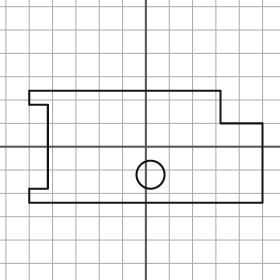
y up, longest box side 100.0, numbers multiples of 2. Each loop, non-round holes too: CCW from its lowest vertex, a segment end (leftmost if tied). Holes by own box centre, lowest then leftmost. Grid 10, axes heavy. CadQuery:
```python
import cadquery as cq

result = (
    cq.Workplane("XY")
    .moveTo(-50.0, -24.0)
    .lineTo(50.0, -24.0)
    .lineTo(50.0, 10.0)
    .lineTo(32.0, 10.0)
    .lineTo(32.0, 24.0)
    .lineTo(-50.0, 24.0)
    .lineTo(-50.0, 18.0)
    .lineTo(-42.0, 18.0)
    .lineTo(-42.0, -18.0)
    .lineTo(-50.0, -18.0)
    .close()
    .moveTo(2.0, -12.0)
    .circle(6.0)
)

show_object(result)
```